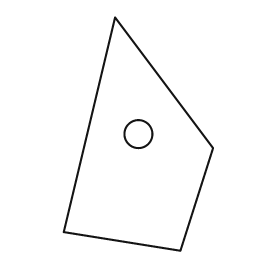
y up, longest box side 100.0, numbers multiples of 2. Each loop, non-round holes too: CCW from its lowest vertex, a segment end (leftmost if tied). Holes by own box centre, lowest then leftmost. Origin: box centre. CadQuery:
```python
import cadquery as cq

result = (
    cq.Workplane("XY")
    .moveTo(18.0, -50.0)
    .lineTo(32.0, -6.0)
    .lineTo(-10.0, 50.0)
    .lineTo(-32.0, -42.0)
    .close()
    .moveTo(0.0, 0.0)
    .circle(6.0)
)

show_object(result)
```